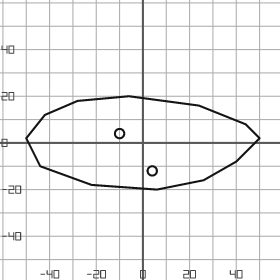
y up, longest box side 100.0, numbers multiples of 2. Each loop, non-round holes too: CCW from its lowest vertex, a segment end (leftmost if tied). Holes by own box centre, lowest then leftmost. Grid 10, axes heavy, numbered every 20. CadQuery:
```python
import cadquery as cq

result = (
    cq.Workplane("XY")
    .moveTo(6.0, -20.0)
    .lineTo(26.0, -16.0)
    .lineTo(40.0, -8.0)
    .lineTo(50.0, 2.0)
    .lineTo(44.0, 8.0)
    .lineTo(24.0, 16.0)
    .lineTo(-6.0, 20.0)
    .lineTo(-28.0, 18.0)
    .lineTo(-42.0, 12.0)
    .lineTo(-50.0, 2.0)
    .lineTo(-44.0, -10.0)
    .lineTo(-22.0, -18.0)
    .close()
    .moveTo(4.0, -12.0)
    .circle(2.0)
    .moveTo(-10.0, 4.0)
    .circle(2.0)
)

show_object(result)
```